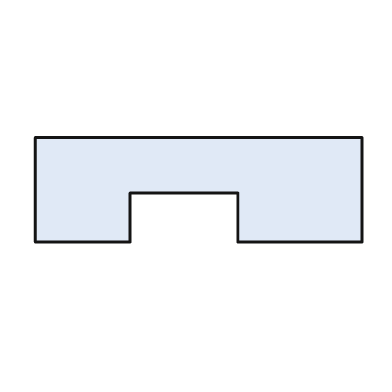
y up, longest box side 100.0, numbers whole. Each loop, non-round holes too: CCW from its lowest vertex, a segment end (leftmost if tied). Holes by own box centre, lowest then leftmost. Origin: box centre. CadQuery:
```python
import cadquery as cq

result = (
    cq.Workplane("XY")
    .moveTo(-50.0, -16.0)
    .lineTo(-21.0, -16.0)
    .lineTo(-21.0, -1.0)
    .lineTo(12.0, -1.0)
    .lineTo(12.0, -16.0)
    .lineTo(50.0, -16.0)
    .lineTo(50.0, 16.0)
    .lineTo(-50.0, 16.0)
    .close()
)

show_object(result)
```